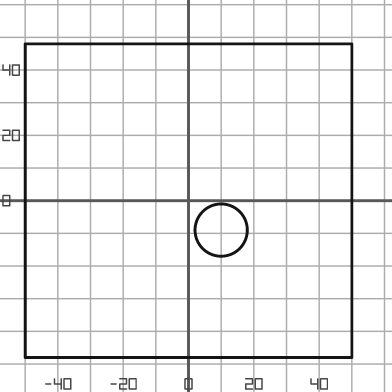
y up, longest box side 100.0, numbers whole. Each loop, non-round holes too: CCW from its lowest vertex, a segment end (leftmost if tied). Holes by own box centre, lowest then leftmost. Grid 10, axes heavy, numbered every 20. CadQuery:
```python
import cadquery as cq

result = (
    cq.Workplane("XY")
    .moveTo(-50.0, -48.0)
    .lineTo(50.0, -48.0)
    .lineTo(50.0, 48.0)
    .lineTo(-50.0, 48.0)
    .close()
    .moveTo(10.0, -9.0)
    .circle(8.0)
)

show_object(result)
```